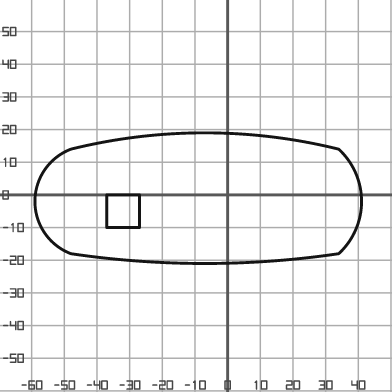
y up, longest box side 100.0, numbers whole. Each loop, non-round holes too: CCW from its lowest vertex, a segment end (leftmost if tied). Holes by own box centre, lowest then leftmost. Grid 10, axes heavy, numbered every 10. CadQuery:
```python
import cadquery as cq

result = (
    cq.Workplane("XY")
    .moveTo(-48.0, -18.0)
    .threePointArc((-7.0, -21.0), (34.0, -18.0))
    .threePointArc((41.0, -2.0), (34.0, 14.0))
    .threePointArc((-7.0, 19.0), (-48.0, 14.0))
    .threePointArc((-59.0, -2.0), (-48.0, -18.0))
    .close()
    .moveTo(-37.0, -10.0)
    .lineTo(-27.0, -10.0)
    .lineTo(-27.0, 0.0)
    .lineTo(-37.0, 0.0)
    .close()
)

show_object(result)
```